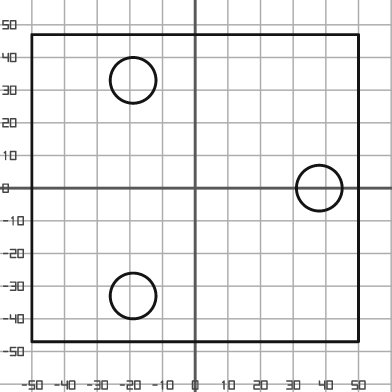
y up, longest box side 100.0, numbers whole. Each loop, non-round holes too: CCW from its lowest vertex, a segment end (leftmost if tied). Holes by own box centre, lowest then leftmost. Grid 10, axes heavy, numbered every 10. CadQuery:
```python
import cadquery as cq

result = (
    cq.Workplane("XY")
    .moveTo(-50.0, -47.0)
    .lineTo(50.0, -47.0)
    .lineTo(50.0, 47.0)
    .lineTo(-50.0, 47.0)
    .close()
    .moveTo(-19.0, -33.0)
    .circle(7.0)
    .moveTo(38.0, 0.0)
    .circle(7.0)
    .moveTo(-19.0, 33.0)
    .circle(7.0)
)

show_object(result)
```